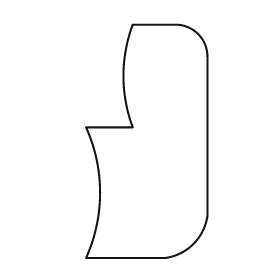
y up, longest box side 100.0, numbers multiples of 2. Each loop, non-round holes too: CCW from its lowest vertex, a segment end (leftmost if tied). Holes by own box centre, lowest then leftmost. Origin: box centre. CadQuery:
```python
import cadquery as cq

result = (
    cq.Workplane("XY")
    .moveTo(-26.0, -50.0)
    .lineTo(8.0, -50.0)
    .threePointArc((20.0, -44.0), (26.0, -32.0))
    .lineTo(26.0, 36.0)
    .threePointArc((22.0, 46.0), (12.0, 50.0))
    .lineTo(-6.0, 50.0)
    .threePointArc((-10.0, 28.0), (-6.0, 6.0))
    .lineTo(-26.0, 6.0)
    .threePointArc((-20.0, -22.0), (-26.0, -50.0))
    .close()
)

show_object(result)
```